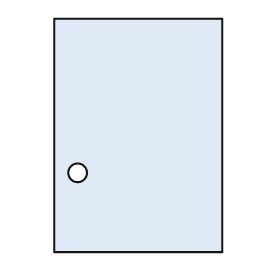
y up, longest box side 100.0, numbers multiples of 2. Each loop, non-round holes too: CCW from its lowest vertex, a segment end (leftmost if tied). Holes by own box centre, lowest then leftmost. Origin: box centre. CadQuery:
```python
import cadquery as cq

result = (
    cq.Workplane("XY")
    .moveTo(-36.0, -50.0)
    .lineTo(36.0, -50.0)
    .lineTo(36.0, 50.0)
    .lineTo(-36.0, 50.0)
    .close()
    .moveTo(-26.0, -16.0)
    .circle(4.0)
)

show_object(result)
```